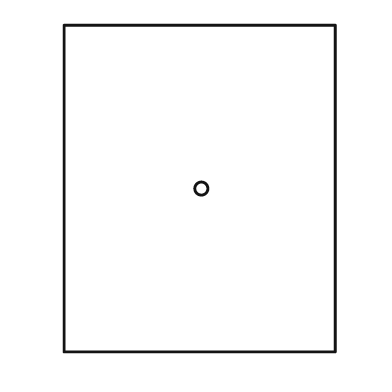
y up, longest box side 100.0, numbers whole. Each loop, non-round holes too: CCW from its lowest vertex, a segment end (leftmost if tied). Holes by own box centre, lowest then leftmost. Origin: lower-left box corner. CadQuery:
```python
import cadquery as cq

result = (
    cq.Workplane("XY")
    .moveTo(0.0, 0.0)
    .lineTo(83.0, 0.0)
    .lineTo(83.0, 100.0)
    .lineTo(0.0, 100.0)
    .close()
    .moveTo(42.0, 50.0)
    .circle(2.0)
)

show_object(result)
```